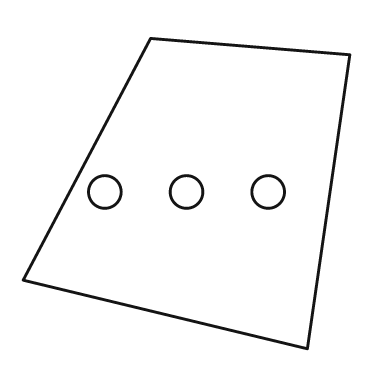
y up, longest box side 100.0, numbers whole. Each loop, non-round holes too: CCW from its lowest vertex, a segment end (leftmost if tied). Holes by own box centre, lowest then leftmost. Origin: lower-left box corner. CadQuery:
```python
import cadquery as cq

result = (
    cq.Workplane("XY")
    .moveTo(87.0, 0.0)
    .lineTo(100.0, 90.0)
    .lineTo(39.0, 95.0)
    .lineTo(0.0, 21.0)
    .close()
    .moveTo(25.0, 48.0)
    .circle(5.0)
    .moveTo(50.0, 48.0)
    .circle(5.0)
    .moveTo(75.0, 48.0)
    .circle(5.0)
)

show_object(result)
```